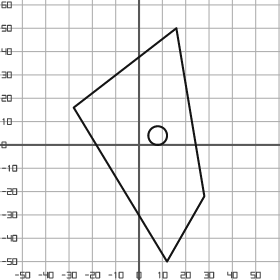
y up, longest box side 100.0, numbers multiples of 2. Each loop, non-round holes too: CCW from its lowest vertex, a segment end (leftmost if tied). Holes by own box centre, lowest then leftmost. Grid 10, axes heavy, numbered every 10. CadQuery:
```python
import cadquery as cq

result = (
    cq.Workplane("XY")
    .moveTo(12.0, -50.0)
    .lineTo(28.0, -22.0)
    .lineTo(16.0, 50.0)
    .lineTo(-28.0, 16.0)
    .close()
    .moveTo(8.0, 4.0)
    .circle(4.0)
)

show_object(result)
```